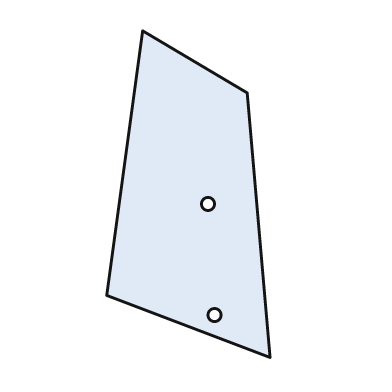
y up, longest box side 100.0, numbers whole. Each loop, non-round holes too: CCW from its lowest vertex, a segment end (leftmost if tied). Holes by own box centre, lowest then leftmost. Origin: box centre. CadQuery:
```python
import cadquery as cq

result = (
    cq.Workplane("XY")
    .moveTo(25.0, -50.0)
    .lineTo(18.0, 31.0)
    .lineTo(-14.0, 50.0)
    .lineTo(-25.0, -31.0)
    .close()
    .moveTo(8.0, -37.0)
    .circle(2.0)
    .moveTo(6.0, -3.0)
    .circle(2.0)
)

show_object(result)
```